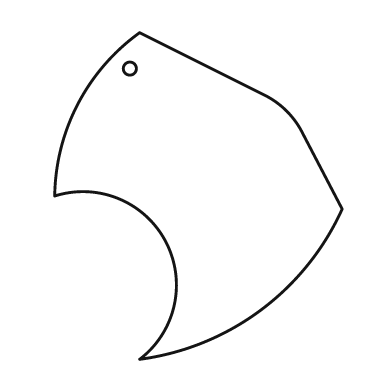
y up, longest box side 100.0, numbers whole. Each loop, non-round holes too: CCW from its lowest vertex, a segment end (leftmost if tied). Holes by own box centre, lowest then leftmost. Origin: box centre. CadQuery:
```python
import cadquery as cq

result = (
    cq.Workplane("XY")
    .moveTo(-18.0, -50.0)
    .threePointArc((19.0, -35.0), (44.0, -4.0))
    .lineTo(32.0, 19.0)
    .threePointArc((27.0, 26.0), (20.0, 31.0))
    .lineTo(-18.0, 50.0)
    .threePointArc((-37.0, 28.0), (-44.0, 0.0))
    .threePointArc((-10.0, -14.0), (-18.0, -50.0))
    .close()
    .moveTo(-21.0, 39.0)
    .circle(2.0)
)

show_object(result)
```